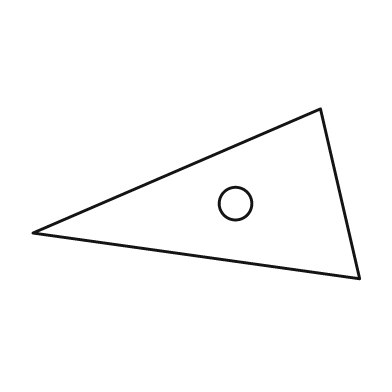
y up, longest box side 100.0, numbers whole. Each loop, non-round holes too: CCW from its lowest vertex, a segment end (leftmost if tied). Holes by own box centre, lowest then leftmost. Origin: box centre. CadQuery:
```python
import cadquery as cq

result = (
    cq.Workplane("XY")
    .moveTo(50.0, -26.0)
    .lineTo(38.0, 26.0)
    .lineTo(-50.0, -12.0)
    .close()
    .moveTo(12.0, -3.0)
    .circle(5.0)
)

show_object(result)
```